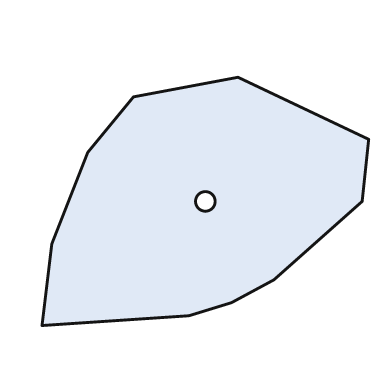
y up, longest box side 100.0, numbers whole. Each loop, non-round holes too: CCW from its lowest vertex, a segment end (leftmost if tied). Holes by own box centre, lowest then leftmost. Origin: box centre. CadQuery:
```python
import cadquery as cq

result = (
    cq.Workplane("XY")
    .moveTo(-50.0, -38.0)
    .lineTo(-5.0, -35.0)
    .lineTo(8.0, -31.0)
    .lineTo(21.0, -24.0)
    .lineTo(48.0, 0.0)
    .lineTo(50.0, 19.0)
    .lineTo(10.0, 38.0)
    .lineTo(-22.0, 32.0)
    .lineTo(-36.0, 15.0)
    .lineTo(-47.0, -13.0)
    .close()
    .moveTo(0.0, 0.0)
    .circle(3.0)
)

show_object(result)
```